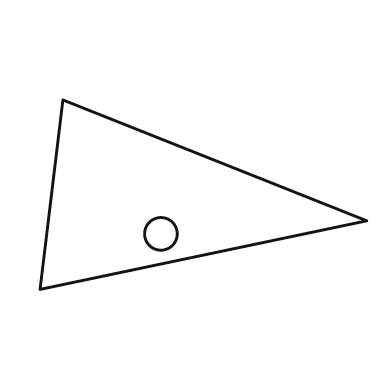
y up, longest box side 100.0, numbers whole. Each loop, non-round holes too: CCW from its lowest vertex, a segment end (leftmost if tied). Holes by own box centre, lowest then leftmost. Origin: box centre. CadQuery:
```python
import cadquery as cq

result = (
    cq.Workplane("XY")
    .moveTo(-50.0, -29.0)
    .lineTo(50.0, -8.0)
    .lineTo(-43.0, 29.0)
    .close()
    .moveTo(-13.0, -12.0)
    .circle(5.0)
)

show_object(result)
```